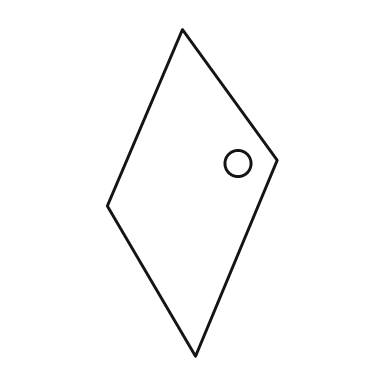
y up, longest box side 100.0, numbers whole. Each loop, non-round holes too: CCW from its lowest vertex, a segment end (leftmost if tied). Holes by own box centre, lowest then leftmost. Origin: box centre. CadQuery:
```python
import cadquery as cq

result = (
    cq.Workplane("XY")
    .moveTo(1.0, -50.0)
    .lineTo(26.0, 10.0)
    .lineTo(-3.0, 50.0)
    .lineTo(-26.0, -4.0)
    .close()
    .moveTo(14.0, 9.0)
    .circle(4.0)
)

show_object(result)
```